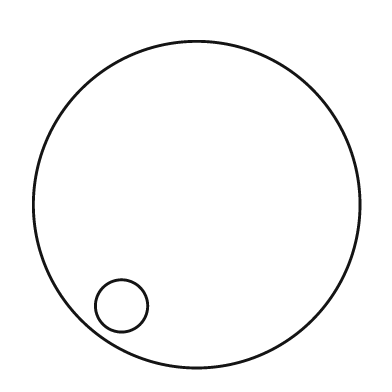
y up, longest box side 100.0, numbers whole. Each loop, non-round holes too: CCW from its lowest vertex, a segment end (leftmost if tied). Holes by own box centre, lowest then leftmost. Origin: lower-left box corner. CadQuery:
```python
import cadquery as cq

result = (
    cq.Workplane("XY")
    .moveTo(50.0, 50.0)
    .circle(50.0)
    .moveTo(27.0, 19.0)
    .circle(8.0)
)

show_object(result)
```